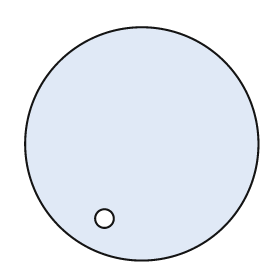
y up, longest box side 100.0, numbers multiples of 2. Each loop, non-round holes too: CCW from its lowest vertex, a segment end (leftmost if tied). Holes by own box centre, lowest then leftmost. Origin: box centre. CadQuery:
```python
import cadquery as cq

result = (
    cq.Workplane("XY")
    .moveTo(0.0, 0.0)
    .circle(50.0)
    .moveTo(-16.0, -32.0)
    .circle(4.0)
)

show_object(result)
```